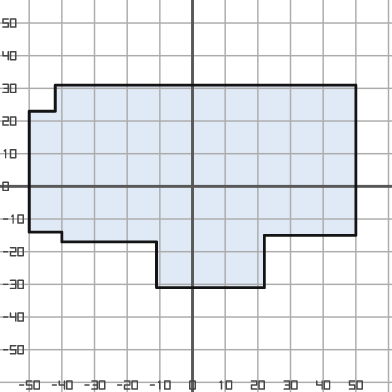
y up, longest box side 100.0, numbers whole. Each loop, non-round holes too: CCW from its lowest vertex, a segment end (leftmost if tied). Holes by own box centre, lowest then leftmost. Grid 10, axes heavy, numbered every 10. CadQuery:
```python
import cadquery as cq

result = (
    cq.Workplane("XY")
    .moveTo(-11.0, -31.0)
    .lineTo(22.0, -31.0)
    .lineTo(22.0, -15.0)
    .lineTo(50.0, -15.0)
    .lineTo(50.0, 31.0)
    .lineTo(-42.0, 31.0)
    .lineTo(-42.0, 23.0)
    .lineTo(-50.0, 23.0)
    .lineTo(-50.0, -14.0)
    .lineTo(-40.0, -14.0)
    .lineTo(-40.0, -17.0)
    .lineTo(-11.0, -17.0)
    .close()
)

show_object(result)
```